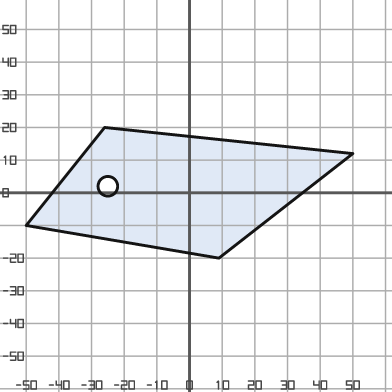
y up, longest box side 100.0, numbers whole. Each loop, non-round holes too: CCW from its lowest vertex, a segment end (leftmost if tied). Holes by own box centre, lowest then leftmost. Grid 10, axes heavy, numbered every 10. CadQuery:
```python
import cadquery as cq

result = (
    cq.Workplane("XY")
    .moveTo(9.0, -20.0)
    .lineTo(50.0, 12.0)
    .lineTo(-26.0, 20.0)
    .lineTo(-50.0, -10.0)
    .close()
    .moveTo(-25.0, 2.0)
    .circle(3.0)
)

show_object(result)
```